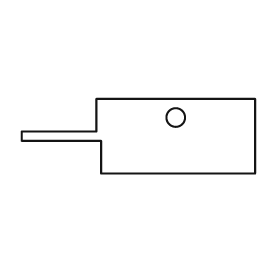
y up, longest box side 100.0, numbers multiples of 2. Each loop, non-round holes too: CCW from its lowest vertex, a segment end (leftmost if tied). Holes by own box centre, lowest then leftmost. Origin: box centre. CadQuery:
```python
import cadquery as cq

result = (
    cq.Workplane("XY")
    .moveTo(-16.0, -16.0)
    .lineTo(50.0, -16.0)
    .lineTo(50.0, 16.0)
    .lineTo(-18.0, 16.0)
    .lineTo(-18.0, 2.0)
    .lineTo(-50.0, 2.0)
    .lineTo(-50.0, -2.0)
    .lineTo(-16.0, -2.0)
    .close()
    .moveTo(16.0, 8.0)
    .circle(4.0)
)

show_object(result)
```